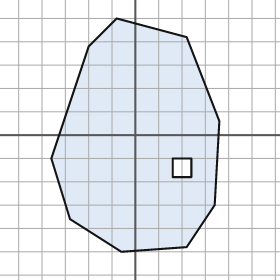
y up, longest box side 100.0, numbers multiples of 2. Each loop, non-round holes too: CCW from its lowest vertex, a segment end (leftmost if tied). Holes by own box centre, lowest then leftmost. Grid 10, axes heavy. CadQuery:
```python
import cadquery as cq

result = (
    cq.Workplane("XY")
    .moveTo(-6.0, -50.0)
    .lineTo(22.0, -48.0)
    .lineTo(34.0, -30.0)
    .lineTo(36.0, 6.0)
    .lineTo(22.0, 42.0)
    .lineTo(-8.0, 50.0)
    .lineTo(-20.0, 38.0)
    .lineTo(-36.0, -10.0)
    .lineTo(-28.0, -36.0)
    .close()
    .moveTo(16.0, -18.0)
    .lineTo(24.0, -18.0)
    .lineTo(24.0, -10.0)
    .lineTo(16.0, -10.0)
    .close()
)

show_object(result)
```